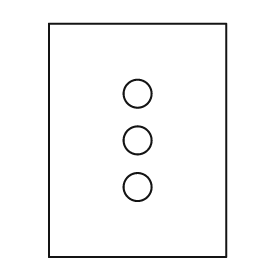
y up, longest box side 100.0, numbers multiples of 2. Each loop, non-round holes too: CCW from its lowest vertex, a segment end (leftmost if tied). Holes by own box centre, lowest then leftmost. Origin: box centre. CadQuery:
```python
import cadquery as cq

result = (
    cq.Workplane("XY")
    .moveTo(-38.0, -50.0)
    .lineTo(38.0, -50.0)
    .lineTo(38.0, 50.0)
    .lineTo(-38.0, 50.0)
    .close()
    .moveTo(0.0, -20.0)
    .circle(6.0)
    .moveTo(0.0, 0.0)
    .circle(6.0)
    .moveTo(0.0, 20.0)
    .circle(6.0)
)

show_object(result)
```